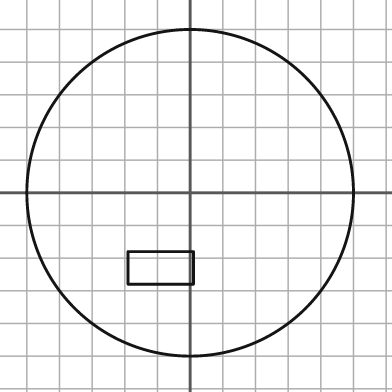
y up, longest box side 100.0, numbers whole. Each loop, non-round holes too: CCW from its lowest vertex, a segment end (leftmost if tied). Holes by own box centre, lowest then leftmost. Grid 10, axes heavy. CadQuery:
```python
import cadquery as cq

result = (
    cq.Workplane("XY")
    .moveTo(0.0, 0.0)
    .circle(50.0)
    .moveTo(-19.0, -28.0)
    .lineTo(1.0, -28.0)
    .lineTo(1.0, -18.0)
    .lineTo(-19.0, -18.0)
    .close()
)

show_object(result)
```